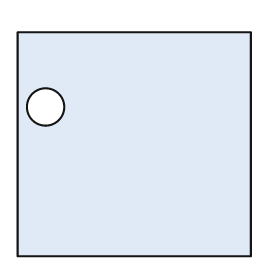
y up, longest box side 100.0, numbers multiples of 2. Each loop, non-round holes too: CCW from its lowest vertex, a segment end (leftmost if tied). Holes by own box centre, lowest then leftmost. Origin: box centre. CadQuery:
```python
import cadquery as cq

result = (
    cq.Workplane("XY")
    .moveTo(-50.0, -48.0)
    .lineTo(50.0, -48.0)
    .lineTo(50.0, 48.0)
    .lineTo(-50.0, 48.0)
    .close()
    .moveTo(-38.0, 16.0)
    .circle(8.0)
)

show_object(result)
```